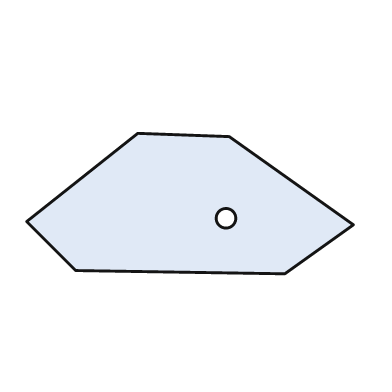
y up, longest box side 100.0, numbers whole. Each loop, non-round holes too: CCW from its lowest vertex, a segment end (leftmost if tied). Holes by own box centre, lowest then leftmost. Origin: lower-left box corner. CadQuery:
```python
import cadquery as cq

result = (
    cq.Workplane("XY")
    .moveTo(79.0, 0.0)
    .lineTo(100.0, 15.0)
    .lineTo(62.0, 42.0)
    .lineTo(34.0, 43.0)
    .lineTo(0.0, 16.0)
    .lineTo(15.0, 1.0)
    .close()
    .moveTo(61.0, 17.0)
    .circle(3.0)
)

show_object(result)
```